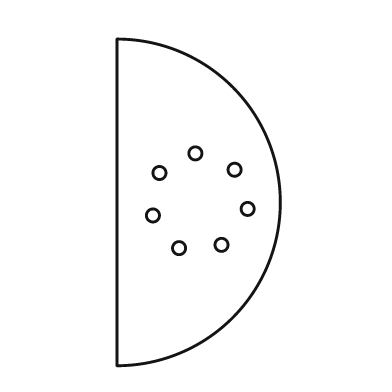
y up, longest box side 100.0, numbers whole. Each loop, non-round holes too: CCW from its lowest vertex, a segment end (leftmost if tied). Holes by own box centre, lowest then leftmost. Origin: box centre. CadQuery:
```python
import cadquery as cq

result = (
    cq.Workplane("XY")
    .moveTo(-25.0, -50.0)
    .threePointArc((25.0, 0.0), (-25.0, 50.0))
    .close()
    .moveTo(-6.0, -14.0)
    .circle(2.0)
    .moveTo(7.0, -13.0)
    .circle(2.0)
    .moveTo(-14.0, -4.0)
    .circle(2.0)
    .moveTo(15.0, -2.0)
    .circle(2.0)
    .moveTo(-12.0, 9.0)
    .circle(2.0)
    .moveTo(11.0, 10.0)
    .circle(2.0)
    .moveTo(-1.0, 15.0)
    .circle(2.0)
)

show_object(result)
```